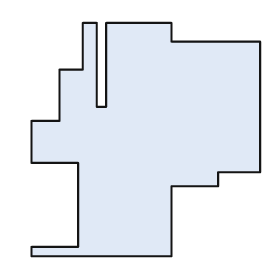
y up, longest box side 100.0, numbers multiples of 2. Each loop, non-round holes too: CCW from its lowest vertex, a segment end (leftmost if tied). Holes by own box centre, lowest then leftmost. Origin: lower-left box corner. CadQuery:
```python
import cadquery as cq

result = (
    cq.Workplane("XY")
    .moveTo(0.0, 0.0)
    .lineTo(60.0, 0.0)
    .lineTo(60.0, 30.0)
    .lineTo(80.0, 30.0)
    .lineTo(80.0, 36.0)
    .lineTo(98.0, 36.0)
    .lineTo(98.0, 92.0)
    .lineTo(60.0, 92.0)
    .lineTo(60.0, 100.0)
    .lineTo(32.0, 100.0)
    .lineTo(32.0, 64.0)
    .lineTo(28.0, 64.0)
    .lineTo(28.0, 100.0)
    .lineTo(22.0, 100.0)
    .lineTo(22.0, 80.0)
    .lineTo(12.0, 80.0)
    .lineTo(12.0, 58.0)
    .lineTo(0.0, 58.0)
    .lineTo(0.0, 40.0)
    .lineTo(20.0, 40.0)
    .lineTo(20.0, 4.0)
    .lineTo(0.0, 4.0)
    .close()
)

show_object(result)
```